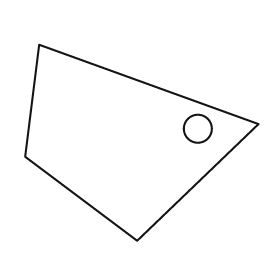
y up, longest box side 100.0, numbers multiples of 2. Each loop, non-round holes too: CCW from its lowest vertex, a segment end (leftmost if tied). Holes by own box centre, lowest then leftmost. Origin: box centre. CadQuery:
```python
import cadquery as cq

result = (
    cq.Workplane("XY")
    .moveTo(-2.0, -42.0)
    .lineTo(50.0, 8.0)
    .lineTo(-44.0, 42.0)
    .lineTo(-50.0, -6.0)
    .close()
    .moveTo(24.0, 6.0)
    .circle(6.0)
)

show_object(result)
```